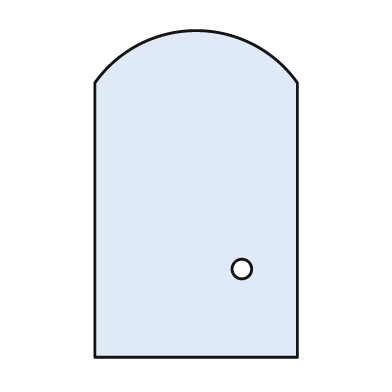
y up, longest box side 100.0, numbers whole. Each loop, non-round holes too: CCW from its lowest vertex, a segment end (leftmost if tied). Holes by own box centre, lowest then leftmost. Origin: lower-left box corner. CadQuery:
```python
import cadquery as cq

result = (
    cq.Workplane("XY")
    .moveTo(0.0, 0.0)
    .lineTo(62.0, 0.0)
    .lineTo(62.0, 84.0)
    .threePointArc((31.0, 100.0), (0.0, 84.0))
    .close()
    .moveTo(45.0, 27.0)
    .circle(3.0)
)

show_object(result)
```